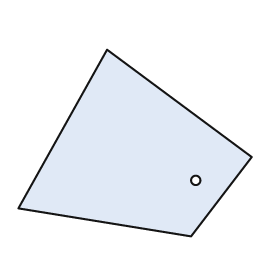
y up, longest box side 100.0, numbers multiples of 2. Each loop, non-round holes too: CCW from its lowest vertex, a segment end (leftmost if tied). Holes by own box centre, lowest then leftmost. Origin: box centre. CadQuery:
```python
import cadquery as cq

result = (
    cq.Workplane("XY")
    .moveTo(24.0, -40.0)
    .lineTo(50.0, -6.0)
    .lineTo(-12.0, 40.0)
    .lineTo(-50.0, -28.0)
    .close()
    .moveTo(26.0, -16.0)
    .circle(2.0)
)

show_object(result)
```